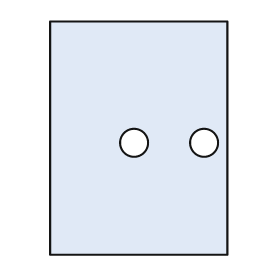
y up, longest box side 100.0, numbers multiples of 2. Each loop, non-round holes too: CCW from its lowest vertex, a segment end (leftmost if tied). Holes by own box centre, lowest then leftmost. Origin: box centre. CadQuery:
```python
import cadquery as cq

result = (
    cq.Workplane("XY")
    .moveTo(-38.0, -50.0)
    .lineTo(38.0, -50.0)
    .lineTo(38.0, 50.0)
    .lineTo(-38.0, 50.0)
    .close()
    .moveTo(-2.0, -2.0)
    .circle(6.0)
    .moveTo(28.0, -2.0)
    .circle(6.0)
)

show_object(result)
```